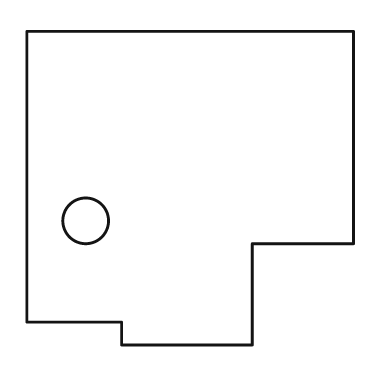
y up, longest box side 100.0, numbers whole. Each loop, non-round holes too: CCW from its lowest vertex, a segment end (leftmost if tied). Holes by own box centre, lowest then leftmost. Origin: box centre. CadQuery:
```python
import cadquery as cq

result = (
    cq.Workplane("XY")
    .moveTo(-21.0, -48.0)
    .lineTo(19.0, -48.0)
    .lineTo(19.0, -17.0)
    .lineTo(50.0, -17.0)
    .lineTo(50.0, 48.0)
    .lineTo(-50.0, 48.0)
    .lineTo(-50.0, -41.0)
    .lineTo(-21.0, -41.0)
    .close()
    .moveTo(-32.0, -10.0)
    .circle(7.0)
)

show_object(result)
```